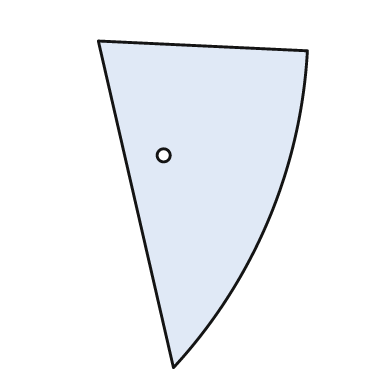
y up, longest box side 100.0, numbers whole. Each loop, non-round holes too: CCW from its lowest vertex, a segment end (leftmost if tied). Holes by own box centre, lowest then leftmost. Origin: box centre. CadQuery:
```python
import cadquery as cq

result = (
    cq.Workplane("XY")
    .moveTo(-9.0, -50.0)
    .threePointArc((20.0, -5.0), (32.0, 47.0))
    .lineTo(-32.0, 50.0)
    .close()
    .moveTo(-12.0, 15.0)
    .circle(2.0)
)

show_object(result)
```